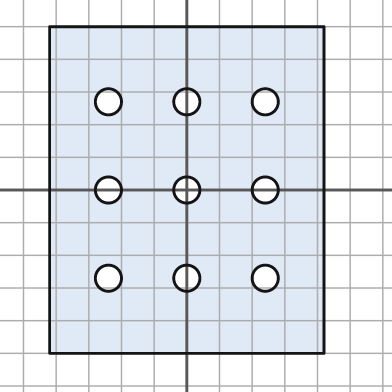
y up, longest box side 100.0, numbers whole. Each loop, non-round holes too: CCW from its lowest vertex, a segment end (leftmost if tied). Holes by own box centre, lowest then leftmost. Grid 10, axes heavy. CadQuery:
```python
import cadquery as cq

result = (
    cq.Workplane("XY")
    .moveTo(-42.0, -50.0)
    .lineTo(42.0, -50.0)
    .lineTo(42.0, 50.0)
    .lineTo(-42.0, 50.0)
    .close()
    .moveTo(-24.0, -27.0)
    .circle(4.0)
    .moveTo(0.0, -27.0)
    .circle(4.0)
    .moveTo(24.0, -27.0)
    .circle(4.0)
    .moveTo(-24.0, 0.0)
    .circle(4.0)
    .moveTo(0.0, 0.0)
    .circle(4.0)
    .moveTo(24.0, 0.0)
    .circle(4.0)
    .moveTo(-24.0, 27.0)
    .circle(4.0)
    .moveTo(0.0, 27.0)
    .circle(4.0)
    .moveTo(24.0, 27.0)
    .circle(4.0)
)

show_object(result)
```